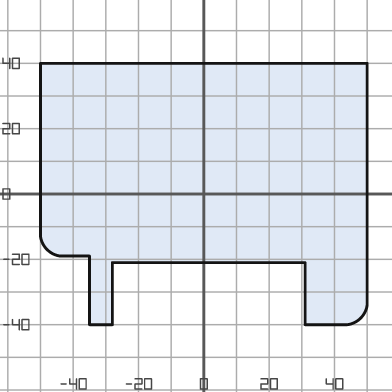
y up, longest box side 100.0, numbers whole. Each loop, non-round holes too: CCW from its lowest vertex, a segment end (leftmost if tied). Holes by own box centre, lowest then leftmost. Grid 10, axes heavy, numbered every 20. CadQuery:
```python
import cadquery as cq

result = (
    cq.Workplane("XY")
    .moveTo(-35.0, -40.0)
    .lineTo(-28.0, -40.0)
    .lineTo(-28.0, -21.0)
    .lineTo(31.0, -21.0)
    .lineTo(31.0, -40.0)
    .lineTo(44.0, -40.0)
    .threePointArc((48.0, -38.0), (50.0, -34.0))
    .lineTo(50.0, 40.0)
    .lineTo(-50.0, 40.0)
    .lineTo(-50.0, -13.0)
    .threePointArc((-48.0, -17.0), (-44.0, -19.0))
    .lineTo(-35.0, -19.0)
    .close()
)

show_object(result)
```